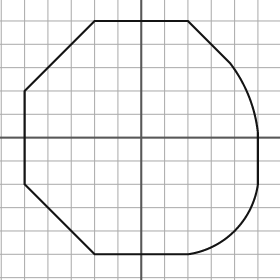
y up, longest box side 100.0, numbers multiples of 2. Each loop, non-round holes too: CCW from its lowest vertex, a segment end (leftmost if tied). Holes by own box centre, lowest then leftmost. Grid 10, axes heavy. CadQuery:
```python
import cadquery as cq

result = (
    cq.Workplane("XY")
    .moveTo(-20.0, -50.0)
    .lineTo(20.0, -50.0)
    .threePointArc((40.0, -40.0), (50.0, -20.0))
    .lineTo(50.0, 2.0)
    .threePointArc((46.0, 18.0), (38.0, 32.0))
    .lineTo(20.0, 50.0)
    .lineTo(-20.0, 50.0)
    .lineTo(-50.0, 20.0)
    .lineTo(-50.0, -20.0)
    .close()
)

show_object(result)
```